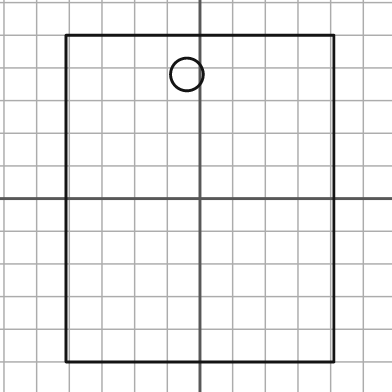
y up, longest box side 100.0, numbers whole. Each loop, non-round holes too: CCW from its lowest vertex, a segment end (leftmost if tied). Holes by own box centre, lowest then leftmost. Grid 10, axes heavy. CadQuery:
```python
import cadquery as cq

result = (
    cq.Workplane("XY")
    .moveTo(-41.0, -50.0)
    .lineTo(41.0, -50.0)
    .lineTo(41.0, 50.0)
    .lineTo(-41.0, 50.0)
    .close()
    .moveTo(-4.0, 38.0)
    .circle(5.0)
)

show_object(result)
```